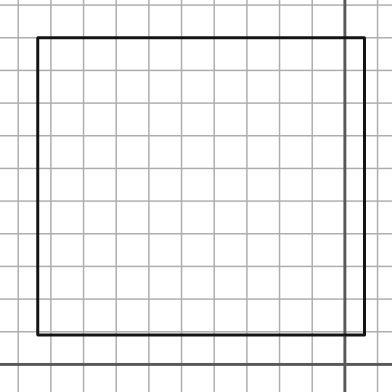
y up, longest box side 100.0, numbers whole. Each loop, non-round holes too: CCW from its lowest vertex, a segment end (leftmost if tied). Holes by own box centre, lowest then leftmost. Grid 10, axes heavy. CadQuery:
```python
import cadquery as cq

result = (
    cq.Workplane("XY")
    .moveTo(-94.0, 9.0)
    .lineTo(6.0, 9.0)
    .lineTo(6.0, 100.0)
    .lineTo(-94.0, 100.0)
    .close()
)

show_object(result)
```